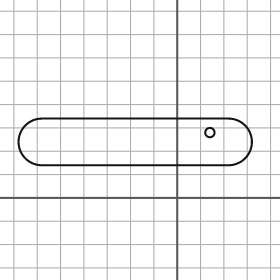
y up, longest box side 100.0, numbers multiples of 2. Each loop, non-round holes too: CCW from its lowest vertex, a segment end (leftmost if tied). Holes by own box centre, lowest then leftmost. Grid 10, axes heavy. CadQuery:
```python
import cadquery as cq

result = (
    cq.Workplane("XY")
    .moveTo(-58.0, 14.0)
    .lineTo(22.0, 14.0)
    .threePointArc((32.0, 24.0), (22.0, 34.0))
    .lineTo(-58.0, 34.0)
    .threePointArc((-68.0, 24.0), (-58.0, 14.0))
    .close()
    .moveTo(14.0, 28.0)
    .circle(2.0)
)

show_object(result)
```